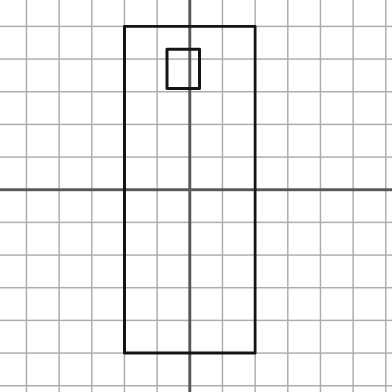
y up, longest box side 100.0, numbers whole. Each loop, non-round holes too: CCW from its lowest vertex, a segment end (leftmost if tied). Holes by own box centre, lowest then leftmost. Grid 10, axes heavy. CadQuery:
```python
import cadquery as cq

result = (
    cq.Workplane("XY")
    .moveTo(-20.0, -50.0)
    .lineTo(20.0, -50.0)
    .lineTo(20.0, 50.0)
    .lineTo(-20.0, 50.0)
    .close()
    .moveTo(-7.0, 31.0)
    .lineTo(3.0, 31.0)
    .lineTo(3.0, 43.0)
    .lineTo(-7.0, 43.0)
    .close()
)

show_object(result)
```